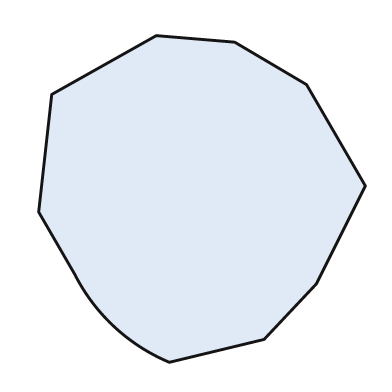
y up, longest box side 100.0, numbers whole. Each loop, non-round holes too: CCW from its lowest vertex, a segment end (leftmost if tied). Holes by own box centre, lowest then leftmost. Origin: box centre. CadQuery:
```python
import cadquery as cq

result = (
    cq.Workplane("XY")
    .moveTo(-10.0, -50.0)
    .lineTo(19.0, -43.0)
    .lineTo(35.0, -26.0)
    .lineTo(50.0, 4.0)
    .lineTo(32.0, 35.0)
    .lineTo(10.0, 48.0)
    .lineTo(-14.0, 50.0)
    .lineTo(-46.0, 32.0)
    .lineTo(-50.0, -4.0)
    .lineTo(-39.0, -23.0)
    .threePointArc((-27.0, -39.0), (-10.0, -50.0))
    .close()
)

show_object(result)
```